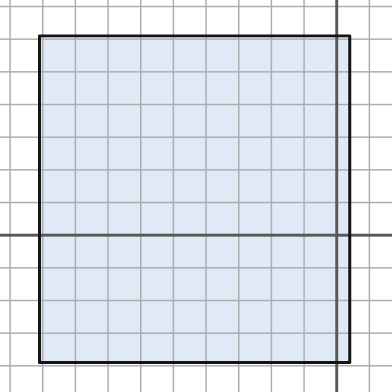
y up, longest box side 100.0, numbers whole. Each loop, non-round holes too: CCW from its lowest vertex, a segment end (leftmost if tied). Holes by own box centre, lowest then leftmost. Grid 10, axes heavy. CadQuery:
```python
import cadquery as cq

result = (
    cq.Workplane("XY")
    .moveTo(-91.0, -39.0)
    .lineTo(4.0, -39.0)
    .lineTo(4.0, 61.0)
    .lineTo(-91.0, 61.0)
    .close()
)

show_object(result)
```